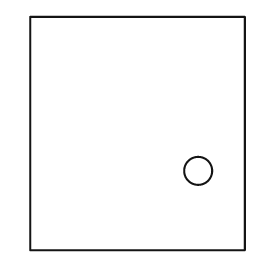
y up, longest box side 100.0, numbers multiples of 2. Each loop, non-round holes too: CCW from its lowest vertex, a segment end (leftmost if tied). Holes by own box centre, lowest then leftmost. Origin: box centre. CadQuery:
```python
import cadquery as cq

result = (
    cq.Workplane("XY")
    .moveTo(-46.0, -50.0)
    .lineTo(46.0, -50.0)
    .lineTo(46.0, 50.0)
    .lineTo(-46.0, 50.0)
    .close()
    .moveTo(26.0, -16.0)
    .circle(6.0)
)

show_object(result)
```